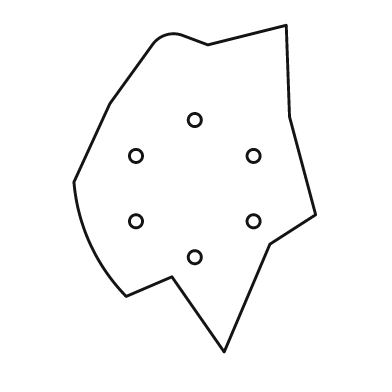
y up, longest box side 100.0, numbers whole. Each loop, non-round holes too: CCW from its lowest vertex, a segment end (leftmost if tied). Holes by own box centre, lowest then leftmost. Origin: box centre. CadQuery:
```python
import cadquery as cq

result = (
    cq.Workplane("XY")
    .moveTo(9.0, -50.0)
    .lineTo(23.0, -17.0)
    .lineTo(37.0, -8.0)
    .lineTo(29.0, 22.0)
    .lineTo(28.0, 50.0)
    .lineTo(4.0, 44.0)
    .lineTo(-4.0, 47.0)
    .threePointArc((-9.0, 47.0), (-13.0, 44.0))
    .lineTo(-26.0, 26.0)
    .lineTo(-37.0, 2.0)
    .threePointArc((-32.0, -17.0), (-21.0, -33.0))
    .lineTo(-7.0, -27.0)
    .close()
    .moveTo(0.0, -21.0)
    .circle(2.0)
    .moveTo(-18.0, -10.0)
    .circle(2.0)
    .moveTo(18.0, -10.0)
    .circle(2.0)
    .moveTo(-18.0, 10.0)
    .circle(2.0)
    .moveTo(18.0, 10.0)
    .circle(2.0)
    .moveTo(0.0, 21.0)
    .circle(2.0)
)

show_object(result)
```